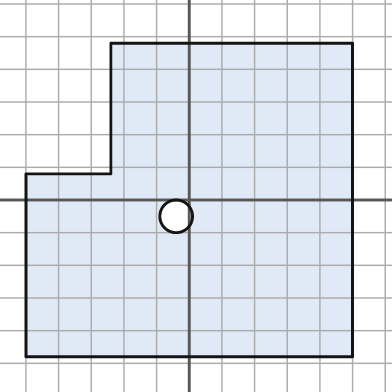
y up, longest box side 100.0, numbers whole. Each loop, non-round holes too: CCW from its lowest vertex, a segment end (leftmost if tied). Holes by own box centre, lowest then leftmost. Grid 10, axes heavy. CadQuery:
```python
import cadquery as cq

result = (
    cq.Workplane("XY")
    .moveTo(-50.0, -48.0)
    .lineTo(50.0, -48.0)
    .lineTo(50.0, 48.0)
    .lineTo(-24.0, 48.0)
    .lineTo(-24.0, 8.0)
    .lineTo(-50.0, 8.0)
    .close()
    .moveTo(-4.0, -5.0)
    .circle(5.0)
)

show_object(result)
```